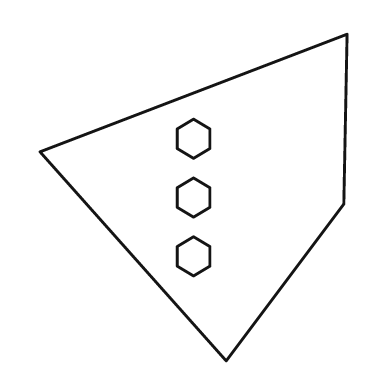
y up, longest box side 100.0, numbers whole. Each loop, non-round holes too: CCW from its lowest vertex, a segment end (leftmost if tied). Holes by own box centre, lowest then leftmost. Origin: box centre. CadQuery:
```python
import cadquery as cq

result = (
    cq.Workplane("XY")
    .moveTo(10.0, -50.0)
    .lineTo(46.0, -2.0)
    .lineTo(47.0, 50.0)
    .lineTo(-47.0, 14.0)
    .close()
    .moveTo(0.0, -24.0)
    .lineTo(5.0, -21.0)
    .lineTo(5.0, -15.0)
    .lineTo(0.0, -12.0)
    .lineTo(-5.0, -15.0)
    .lineTo(-5.0, -21.0)
    .close()
    .moveTo(0.0, -6.0)
    .lineTo(5.0, -3.0)
    .lineTo(5.0, 3.0)
    .lineTo(0.0, 6.0)
    .lineTo(-5.0, 3.0)
    .lineTo(-5.0, -3.0)
    .close()
    .moveTo(0.0, 12.0)
    .lineTo(5.0, 15.0)
    .lineTo(5.0, 21.0)
    .lineTo(0.0, 24.0)
    .lineTo(-5.0, 21.0)
    .lineTo(-5.0, 15.0)
    .close()
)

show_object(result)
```